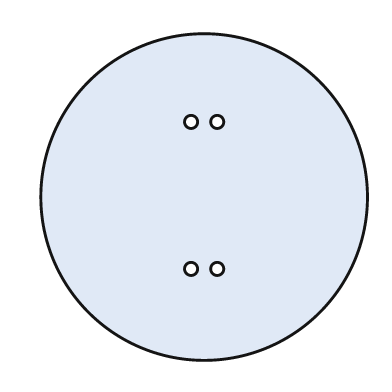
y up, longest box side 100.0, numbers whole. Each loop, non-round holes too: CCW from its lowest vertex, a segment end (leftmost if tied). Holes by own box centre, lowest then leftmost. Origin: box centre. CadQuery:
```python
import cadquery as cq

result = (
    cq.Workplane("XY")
    .moveTo(0.0, 0.0)
    .circle(50.0)
    .moveTo(-4.0, -22.0)
    .circle(2.0)
    .moveTo(4.0, -22.0)
    .circle(2.0)
    .moveTo(-4.0, 23.0)
    .circle(2.0)
    .moveTo(4.0, 23.0)
    .circle(2.0)
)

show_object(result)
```